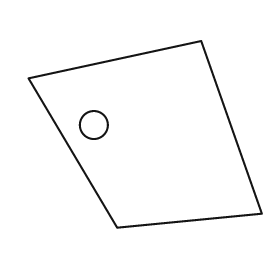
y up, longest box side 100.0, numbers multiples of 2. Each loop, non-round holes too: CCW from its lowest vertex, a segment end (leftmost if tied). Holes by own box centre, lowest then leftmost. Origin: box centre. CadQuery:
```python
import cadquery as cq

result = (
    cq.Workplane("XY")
    .moveTo(-12.0, -40.0)
    .lineTo(50.0, -34.0)
    .lineTo(24.0, 40.0)
    .lineTo(-50.0, 24.0)
    .close()
    .moveTo(-22.0, 4.0)
    .circle(6.0)
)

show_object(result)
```